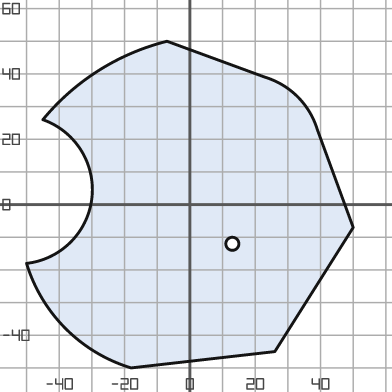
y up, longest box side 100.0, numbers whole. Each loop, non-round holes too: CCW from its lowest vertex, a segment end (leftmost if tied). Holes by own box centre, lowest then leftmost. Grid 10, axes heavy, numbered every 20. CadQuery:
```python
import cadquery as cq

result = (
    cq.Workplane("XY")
    .moveTo(-18.0, -50.0)
    .lineTo(26.0, -45.0)
    .lineTo(50.0, -7.0)
    .lineTo(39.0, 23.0)
    .threePointArc((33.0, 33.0), (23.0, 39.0))
    .lineTo(-7.0, 50.0)
    .threePointArc((-28.0, 41.0), (-45.0, 26.0))
    .threePointArc((-30.0, 2.0), (-50.0, -18.0))
    .threePointArc((-38.0, -38.0), (-18.0, -50.0))
    .close()
    .moveTo(13.0, -12.0)
    .circle(2.0)
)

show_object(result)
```